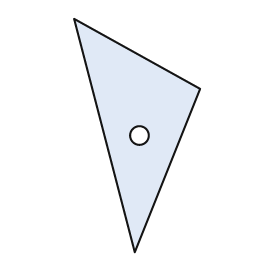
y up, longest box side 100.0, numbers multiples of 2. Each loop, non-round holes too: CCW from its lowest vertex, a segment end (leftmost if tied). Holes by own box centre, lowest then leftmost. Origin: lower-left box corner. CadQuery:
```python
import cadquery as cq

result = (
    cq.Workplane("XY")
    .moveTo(26.0, 0.0)
    .lineTo(54.0, 70.0)
    .lineTo(0.0, 100.0)
    .close()
    .moveTo(28.0, 50.0)
    .circle(4.0)
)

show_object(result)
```